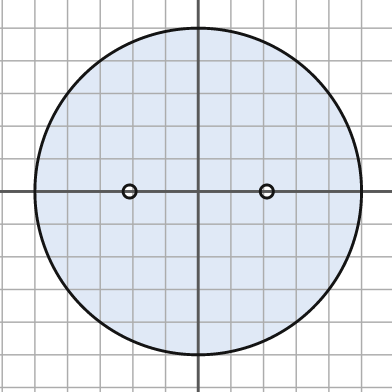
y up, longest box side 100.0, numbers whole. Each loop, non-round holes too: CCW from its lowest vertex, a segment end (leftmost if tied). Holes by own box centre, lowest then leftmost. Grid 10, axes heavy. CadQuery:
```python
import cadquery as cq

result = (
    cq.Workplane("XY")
    .moveTo(0.0, 0.0)
    .circle(50.0)
    .moveTo(-21.0, 0.0)
    .circle(2.0)
    .moveTo(21.0, 0.0)
    .circle(2.0)
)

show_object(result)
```